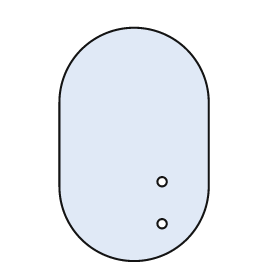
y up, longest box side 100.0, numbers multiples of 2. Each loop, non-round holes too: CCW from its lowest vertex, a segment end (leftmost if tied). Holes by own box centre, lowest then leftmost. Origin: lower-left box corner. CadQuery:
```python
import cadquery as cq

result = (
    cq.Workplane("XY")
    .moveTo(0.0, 32.0)
    .threePointArc((32.0, 0.0), (64.0, 32.0))
    .lineTo(64.0, 68.0)
    .threePointArc((32.0, 100.0), (0.0, 68.0))
    .close()
    .moveTo(44.0, 16.0)
    .circle(2.0)
    .moveTo(44.0, 34.0)
    .circle(2.0)
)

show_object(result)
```